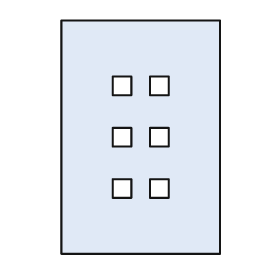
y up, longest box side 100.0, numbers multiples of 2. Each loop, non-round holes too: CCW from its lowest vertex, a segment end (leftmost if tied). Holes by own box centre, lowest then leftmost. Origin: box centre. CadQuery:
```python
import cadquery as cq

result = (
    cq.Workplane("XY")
    .moveTo(-34.0, -50.0)
    .lineTo(34.0, -50.0)
    .lineTo(34.0, 50.0)
    .lineTo(-34.0, 50.0)
    .close()
    .moveTo(-12.0, -26.0)
    .lineTo(-4.0, -26.0)
    .lineTo(-4.0, -18.0)
    .lineTo(-12.0, -18.0)
    .close()
    .moveTo(4.0, -26.0)
    .lineTo(12.0, -26.0)
    .lineTo(12.0, -18.0)
    .lineTo(4.0, -18.0)
    .close()
    .moveTo(-12.0, -4.0)
    .lineTo(-4.0, -4.0)
    .lineTo(-4.0, 4.0)
    .lineTo(-12.0, 4.0)
    .close()
    .moveTo(4.0, -4.0)
    .lineTo(12.0, -4.0)
    .lineTo(12.0, 4.0)
    .lineTo(4.0, 4.0)
    .close()
    .moveTo(-12.0, 18.0)
    .lineTo(-4.0, 18.0)
    .lineTo(-4.0, 26.0)
    .lineTo(-12.0, 26.0)
    .close()
    .moveTo(4.0, 18.0)
    .lineTo(12.0, 18.0)
    .lineTo(12.0, 26.0)
    .lineTo(4.0, 26.0)
    .close()
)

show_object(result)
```